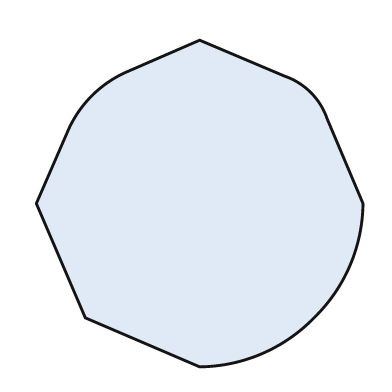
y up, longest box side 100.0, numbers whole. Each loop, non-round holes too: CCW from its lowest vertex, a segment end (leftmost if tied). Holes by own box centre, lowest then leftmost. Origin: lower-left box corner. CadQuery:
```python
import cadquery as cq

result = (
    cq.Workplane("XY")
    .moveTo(50.0, 0.0)
    .threePointArc((69.0, 4.0), (85.0, 15.0))
    .threePointArc((96.0, 31.0), (100.0, 50.0))
    .lineTo(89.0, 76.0)
    .threePointArc((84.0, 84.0), (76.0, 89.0))
    .lineTo(50.0, 100.0)
    .lineTo(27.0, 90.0)
    .threePointArc((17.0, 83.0), (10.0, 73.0))
    .lineTo(0.0, 50.0)
    .lineTo(15.0, 15.0)
    .close()
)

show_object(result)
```